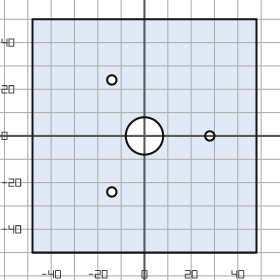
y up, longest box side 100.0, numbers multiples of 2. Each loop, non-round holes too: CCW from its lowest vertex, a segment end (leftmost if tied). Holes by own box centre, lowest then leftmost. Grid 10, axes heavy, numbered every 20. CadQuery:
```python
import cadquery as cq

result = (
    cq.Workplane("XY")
    .moveTo(-48.0, -50.0)
    .lineTo(48.0, -50.0)
    .lineTo(48.0, 50.0)
    .lineTo(-48.0, 50.0)
    .close()
    .moveTo(-14.0, -24.0)
    .circle(2.0)
    .moveTo(0.0, 0.0)
    .circle(8.0)
    .moveTo(28.0, 0.0)
    .circle(2.0)
    .moveTo(-14.0, 24.0)
    .circle(2.0)
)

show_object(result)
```